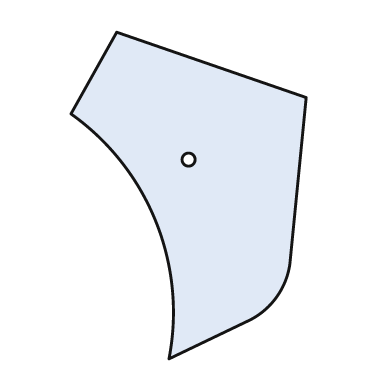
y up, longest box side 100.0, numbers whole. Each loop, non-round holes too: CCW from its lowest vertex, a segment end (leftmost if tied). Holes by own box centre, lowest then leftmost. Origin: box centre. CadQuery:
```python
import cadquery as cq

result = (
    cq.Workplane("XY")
    .moveTo(-6.0, -50.0)
    .lineTo(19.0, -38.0)
    .threePointArc((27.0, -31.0), (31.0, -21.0))
    .lineTo(36.0, 30.0)
    .lineTo(-22.0, 50.0)
    .lineTo(-36.0, 25.0)
    .threePointArc((-10.0, -8.0), (-6.0, -50.0))
    .close()
    .moveTo(0.0, 11.0)
    .circle(2.0)
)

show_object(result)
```